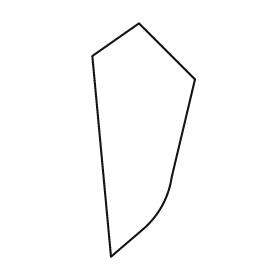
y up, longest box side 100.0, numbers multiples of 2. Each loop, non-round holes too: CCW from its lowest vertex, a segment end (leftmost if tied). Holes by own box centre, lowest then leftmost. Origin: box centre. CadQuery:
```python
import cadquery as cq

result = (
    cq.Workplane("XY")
    .moveTo(-14.0, -50.0)
    .lineTo(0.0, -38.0)
    .threePointArc((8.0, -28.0), (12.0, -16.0))
    .lineTo(22.0, 26.0)
    .lineTo(-2.0, 50.0)
    .lineTo(-22.0, 36.0)
    .close()
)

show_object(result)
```